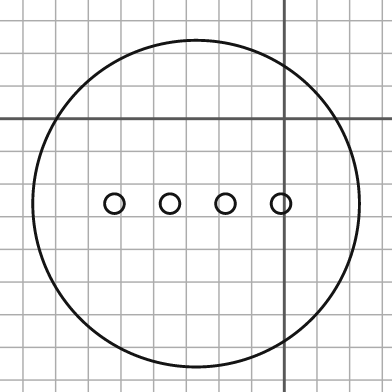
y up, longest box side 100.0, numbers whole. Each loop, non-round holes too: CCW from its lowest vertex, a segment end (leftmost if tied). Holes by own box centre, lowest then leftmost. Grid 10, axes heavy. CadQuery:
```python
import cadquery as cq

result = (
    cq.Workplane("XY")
    .moveTo(-27.0, -26.0)
    .circle(50.0)
    .moveTo(-52.0, -26.0)
    .circle(3.0)
    .moveTo(-35.0, -26.0)
    .circle(3.0)
    .moveTo(-18.0, -26.0)
    .circle(3.0)
    .moveTo(-1.0, -26.0)
    .circle(3.0)
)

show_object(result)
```